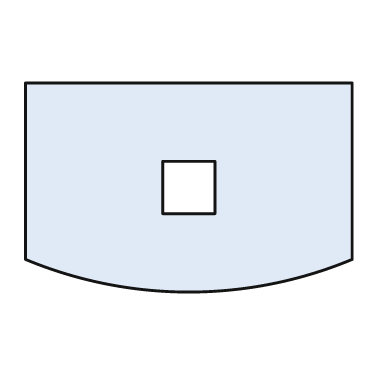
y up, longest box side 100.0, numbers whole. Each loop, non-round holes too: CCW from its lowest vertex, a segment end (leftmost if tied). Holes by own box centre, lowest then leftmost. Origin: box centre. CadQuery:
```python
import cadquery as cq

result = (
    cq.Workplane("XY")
    .moveTo(-50.0, -22.0)
    .threePointArc((0.0, -32.0), (50.0, -22.0))
    .lineTo(50.0, 32.0)
    .lineTo(-50.0, 32.0)
    .close()
    .moveTo(-8.0, -8.0)
    .lineTo(8.0, -8.0)
    .lineTo(8.0, 8.0)
    .lineTo(-8.0, 8.0)
    .close()
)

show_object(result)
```